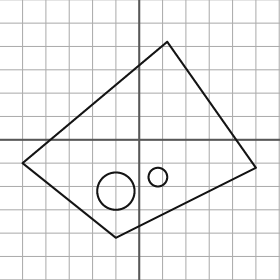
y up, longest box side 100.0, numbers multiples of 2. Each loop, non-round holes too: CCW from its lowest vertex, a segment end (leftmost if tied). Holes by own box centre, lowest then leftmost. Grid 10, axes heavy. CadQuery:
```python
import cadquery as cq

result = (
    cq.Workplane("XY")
    .moveTo(-10.0, -42.0)
    .lineTo(50.0, -12.0)
    .lineTo(12.0, 42.0)
    .lineTo(-50.0, -10.0)
    .close()
    .moveTo(-10.0, -22.0)
    .circle(8.0)
    .moveTo(8.0, -16.0)
    .circle(4.0)
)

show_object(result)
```